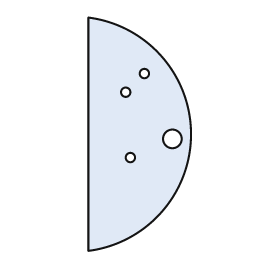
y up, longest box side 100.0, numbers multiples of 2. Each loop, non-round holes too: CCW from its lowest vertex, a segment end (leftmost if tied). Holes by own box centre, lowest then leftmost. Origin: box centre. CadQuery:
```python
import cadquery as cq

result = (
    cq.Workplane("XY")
    .moveTo(-22.0, -50.0)
    .threePointArc((22.0, 0.0), (-22.0, 50.0))
    .close()
    .moveTo(-4.0, -10.0)
    .circle(2.0)
    .moveTo(14.0, -2.0)
    .circle(4.0)
    .moveTo(-6.0, 18.0)
    .circle(2.0)
    .moveTo(2.0, 26.0)
    .circle(2.0)
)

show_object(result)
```